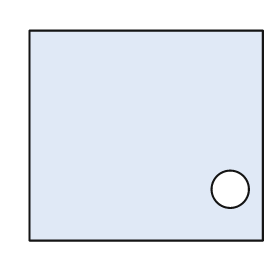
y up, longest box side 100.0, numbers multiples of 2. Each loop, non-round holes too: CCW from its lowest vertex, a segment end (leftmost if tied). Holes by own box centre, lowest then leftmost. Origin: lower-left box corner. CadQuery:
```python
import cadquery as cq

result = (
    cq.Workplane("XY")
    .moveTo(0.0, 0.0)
    .lineTo(100.0, 0.0)
    .lineTo(100.0, 90.0)
    .lineTo(0.0, 90.0)
    .close()
    .moveTo(86.0, 22.0)
    .circle(8.0)
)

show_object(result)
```